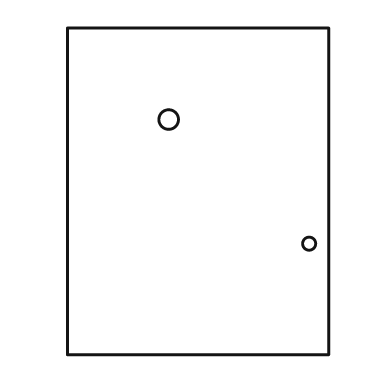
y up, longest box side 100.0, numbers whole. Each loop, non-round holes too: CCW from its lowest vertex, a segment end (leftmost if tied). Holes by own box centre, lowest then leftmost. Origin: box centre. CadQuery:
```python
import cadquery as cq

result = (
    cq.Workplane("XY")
    .moveTo(-40.0, -50.0)
    .lineTo(40.0, -50.0)
    .lineTo(40.0, 50.0)
    .lineTo(-40.0, 50.0)
    .close()
    .moveTo(34.0, -16.0)
    .circle(2.0)
    .moveTo(-9.0, 22.0)
    .circle(3.0)
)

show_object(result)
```